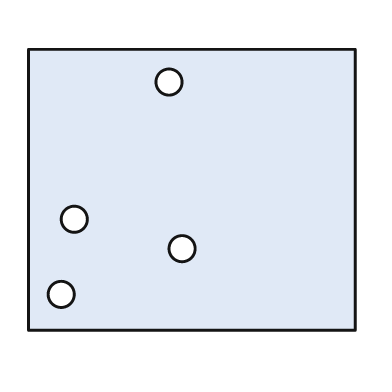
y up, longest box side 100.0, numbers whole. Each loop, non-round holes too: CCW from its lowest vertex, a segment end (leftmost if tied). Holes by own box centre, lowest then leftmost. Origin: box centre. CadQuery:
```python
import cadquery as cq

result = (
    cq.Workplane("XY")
    .moveTo(-50.0, -43.0)
    .lineTo(50.0, -43.0)
    .lineTo(50.0, 43.0)
    .lineTo(-50.0, 43.0)
    .close()
    .moveTo(-40.0, -32.0)
    .circle(4.0)
    .moveTo(-3.0, -18.0)
    .circle(4.0)
    .moveTo(-36.0, -9.0)
    .circle(4.0)
    .moveTo(-7.0, 33.0)
    .circle(4.0)
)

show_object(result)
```